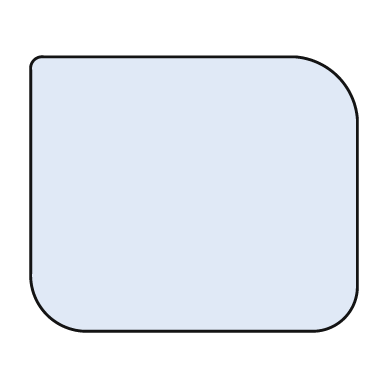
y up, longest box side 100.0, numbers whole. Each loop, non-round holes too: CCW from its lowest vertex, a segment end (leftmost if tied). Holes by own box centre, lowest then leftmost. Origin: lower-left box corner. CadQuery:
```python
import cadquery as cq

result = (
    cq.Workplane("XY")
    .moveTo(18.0, 0.0)
    .lineTo(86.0, 0.0)
    .threePointArc((96.0, 4.0), (100.0, 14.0))
    .lineTo(100.0, 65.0)
    .threePointArc((94.0, 78.0), (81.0, 84.0))
    .lineTo(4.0, 84.0)
    .threePointArc((1.0, 83.0), (0.0, 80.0))
    .lineTo(0.0, 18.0)
    .threePointArc((5.0, 5.0), (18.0, 0.0))
    .close()
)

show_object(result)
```